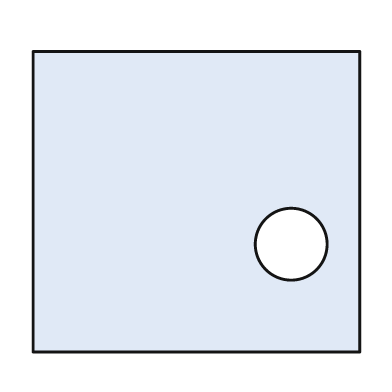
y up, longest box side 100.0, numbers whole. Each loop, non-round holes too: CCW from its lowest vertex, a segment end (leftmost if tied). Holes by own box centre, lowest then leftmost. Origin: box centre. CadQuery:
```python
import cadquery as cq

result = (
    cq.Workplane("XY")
    .moveTo(-50.0, -46.0)
    .lineTo(50.0, -46.0)
    .lineTo(50.0, 46.0)
    .lineTo(-50.0, 46.0)
    .close()
    .moveTo(29.0, -13.0)
    .circle(11.0)
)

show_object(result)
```